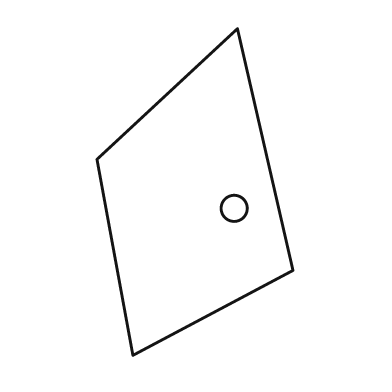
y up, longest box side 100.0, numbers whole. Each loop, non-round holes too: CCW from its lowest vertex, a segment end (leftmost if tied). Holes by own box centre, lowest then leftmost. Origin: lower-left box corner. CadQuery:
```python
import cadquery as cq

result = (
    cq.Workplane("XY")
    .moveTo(11.0, 0.0)
    .lineTo(60.0, 26.0)
    .lineTo(43.0, 100.0)
    .lineTo(0.0, 60.0)
    .close()
    .moveTo(42.0, 45.0)
    .circle(4.0)
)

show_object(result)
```